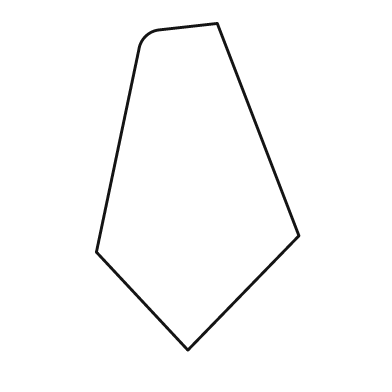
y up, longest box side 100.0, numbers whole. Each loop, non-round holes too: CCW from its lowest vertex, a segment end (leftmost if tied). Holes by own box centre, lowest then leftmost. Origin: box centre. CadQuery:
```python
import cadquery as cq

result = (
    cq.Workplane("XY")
    .moveTo(-3.0, -50.0)
    .lineTo(31.0, -15.0)
    .lineTo(6.0, 50.0)
    .lineTo(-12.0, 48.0)
    .threePointArc((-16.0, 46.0), (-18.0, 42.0))
    .lineTo(-31.0, -20.0)
    .close()
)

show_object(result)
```